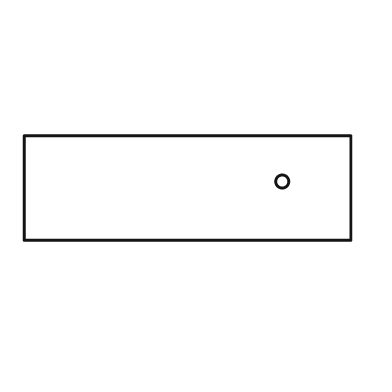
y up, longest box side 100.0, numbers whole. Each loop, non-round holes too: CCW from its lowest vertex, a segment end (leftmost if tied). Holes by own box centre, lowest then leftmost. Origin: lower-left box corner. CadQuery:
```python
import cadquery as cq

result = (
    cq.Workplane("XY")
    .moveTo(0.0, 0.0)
    .lineTo(100.0, 0.0)
    .lineTo(100.0, 32.0)
    .lineTo(0.0, 32.0)
    .close()
    .moveTo(79.0, 18.0)
    .circle(2.0)
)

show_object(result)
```